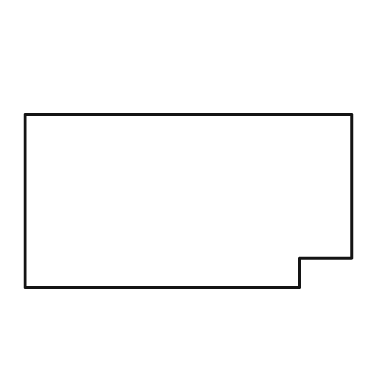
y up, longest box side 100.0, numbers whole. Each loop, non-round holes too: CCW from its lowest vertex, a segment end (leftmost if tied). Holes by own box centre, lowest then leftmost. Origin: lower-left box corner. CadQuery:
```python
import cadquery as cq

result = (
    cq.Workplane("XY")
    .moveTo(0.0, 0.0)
    .lineTo(84.0, 0.0)
    .lineTo(84.0, 9.0)
    .lineTo(100.0, 9.0)
    .lineTo(100.0, 53.0)
    .lineTo(0.0, 53.0)
    .close()
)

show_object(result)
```